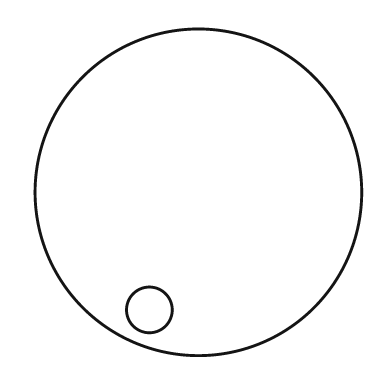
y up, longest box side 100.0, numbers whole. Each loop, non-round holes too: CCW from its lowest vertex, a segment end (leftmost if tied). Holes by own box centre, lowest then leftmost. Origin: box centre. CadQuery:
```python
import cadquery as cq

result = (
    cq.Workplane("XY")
    .moveTo(0.0, 0.0)
    .circle(50.0)
    .moveTo(-15.0, -36.0)
    .circle(7.0)
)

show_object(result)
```